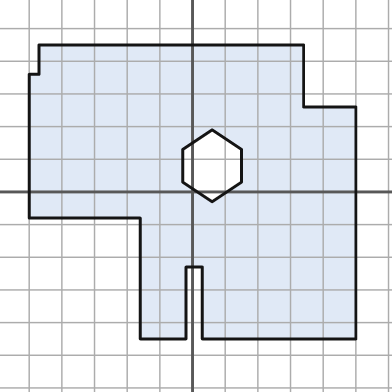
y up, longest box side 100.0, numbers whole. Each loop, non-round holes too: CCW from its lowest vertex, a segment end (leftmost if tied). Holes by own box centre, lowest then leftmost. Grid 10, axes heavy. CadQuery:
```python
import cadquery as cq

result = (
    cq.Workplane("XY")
    .moveTo(-16.0, -45.0)
    .lineTo(-2.0, -45.0)
    .lineTo(-2.0, -23.0)
    .lineTo(3.0, -23.0)
    .lineTo(3.0, -45.0)
    .lineTo(50.0, -45.0)
    .lineTo(50.0, 26.0)
    .lineTo(34.0, 26.0)
    .lineTo(34.0, 45.0)
    .lineTo(-47.0, 45.0)
    .lineTo(-47.0, 36.0)
    .lineTo(-50.0, 36.0)
    .lineTo(-50.0, -8.0)
    .lineTo(-16.0, -8.0)
    .close()
    .moveTo(6.0, -3.0)
    .lineTo(15.0, 3.0)
    .lineTo(15.0, 13.0)
    .lineTo(6.0, 19.0)
    .lineTo(-3.0, 13.0)
    .lineTo(-3.0, 3.0)
    .close()
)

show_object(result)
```